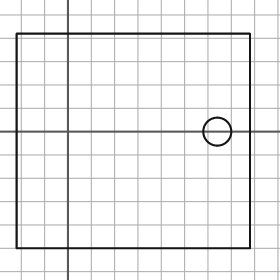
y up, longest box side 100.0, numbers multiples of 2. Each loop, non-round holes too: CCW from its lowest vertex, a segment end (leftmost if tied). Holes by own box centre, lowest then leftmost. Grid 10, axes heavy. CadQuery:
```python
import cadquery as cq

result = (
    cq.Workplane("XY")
    .moveTo(-22.0, -50.0)
    .lineTo(78.0, -50.0)
    .lineTo(78.0, 42.0)
    .lineTo(-22.0, 42.0)
    .close()
    .moveTo(64.0, 0.0)
    .circle(6.0)
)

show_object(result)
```